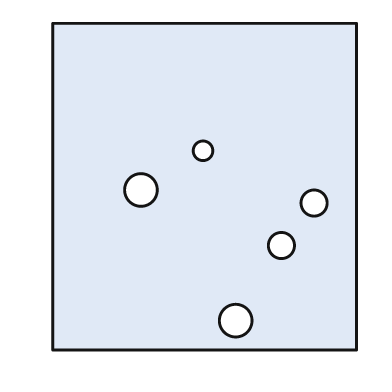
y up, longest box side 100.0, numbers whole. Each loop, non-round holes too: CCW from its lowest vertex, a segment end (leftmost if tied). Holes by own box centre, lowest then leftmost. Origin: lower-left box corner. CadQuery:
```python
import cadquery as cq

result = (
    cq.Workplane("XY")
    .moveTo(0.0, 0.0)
    .lineTo(93.0, 0.0)
    .lineTo(93.0, 100.0)
    .lineTo(0.0, 100.0)
    .close()
    .moveTo(56.0, 9.0)
    .circle(5.0)
    .moveTo(70.0, 32.0)
    .circle(4.0)
    .moveTo(80.0, 45.0)
    .circle(4.0)
    .moveTo(27.0, 49.0)
    .circle(5.0)
    .moveTo(46.0, 61.0)
    .circle(3.0)
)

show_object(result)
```